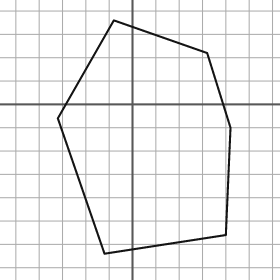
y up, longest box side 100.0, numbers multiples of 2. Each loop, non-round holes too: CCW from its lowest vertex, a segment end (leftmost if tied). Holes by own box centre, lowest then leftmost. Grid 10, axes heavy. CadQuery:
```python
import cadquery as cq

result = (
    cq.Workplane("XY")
    .moveTo(-12.0, -64.0)
    .lineTo(40.0, -56.0)
    .lineTo(42.0, -10.0)
    .lineTo(32.0, 22.0)
    .lineTo(-8.0, 36.0)
    .lineTo(-32.0, -6.0)
    .close()
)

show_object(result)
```